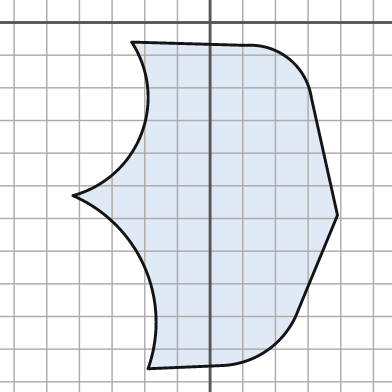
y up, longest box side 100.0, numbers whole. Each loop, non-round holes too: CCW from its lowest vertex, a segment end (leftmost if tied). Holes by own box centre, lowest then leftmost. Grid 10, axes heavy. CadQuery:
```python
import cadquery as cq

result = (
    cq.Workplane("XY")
    .moveTo(-19.0, -106.0)
    .lineTo(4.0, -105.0)
    .threePointArc((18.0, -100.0), (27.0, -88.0))
    .lineTo(39.0, -59.0)
    .lineTo(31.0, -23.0)
    .threePointArc((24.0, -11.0), (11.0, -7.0))
    .lineTo(-24.0, -6.0)
    .threePointArc((-21.0, -34.0), (-42.0, -53.0))
    .threePointArc((-20.0, -75.0), (-19.0, -106.0))
    .close()
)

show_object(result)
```